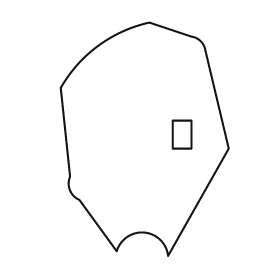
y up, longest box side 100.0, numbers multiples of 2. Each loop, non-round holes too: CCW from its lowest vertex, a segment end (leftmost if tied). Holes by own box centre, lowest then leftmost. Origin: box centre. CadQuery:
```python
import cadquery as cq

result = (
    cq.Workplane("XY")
    .moveTo(10.0, -50.0)
    .lineTo(36.0, -4.0)
    .lineTo(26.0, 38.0)
    .threePointArc((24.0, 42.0), (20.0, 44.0))
    .lineTo(2.0, 50.0)
    .threePointArc((-20.0, 40.0), (-36.0, 22.0))
    .lineTo(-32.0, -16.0)
    .threePointArc((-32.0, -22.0), (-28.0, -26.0))
    .lineTo(-12.0, -48.0)
    .threePointArc((0.0, -40.0), (10.0, -50.0))
    .close()
    .moveTo(12.0, -4.0)
    .lineTo(20.0, -4.0)
    .lineTo(20.0, 8.0)
    .lineTo(12.0, 8.0)
    .close()
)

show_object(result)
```